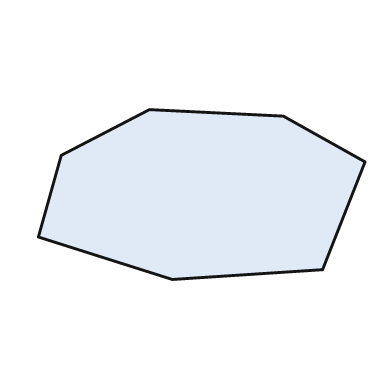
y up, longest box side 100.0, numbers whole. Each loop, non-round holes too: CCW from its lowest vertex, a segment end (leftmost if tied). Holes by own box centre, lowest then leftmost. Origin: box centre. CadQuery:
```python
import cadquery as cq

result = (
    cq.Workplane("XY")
    .moveTo(-9.0, -26.0)
    .lineTo(37.0, -23.0)
    .lineTo(50.0, 10.0)
    .lineTo(25.0, 24.0)
    .lineTo(-16.0, 26.0)
    .lineTo(-43.0, 12.0)
    .lineTo(-50.0, -13.0)
    .close()
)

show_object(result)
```